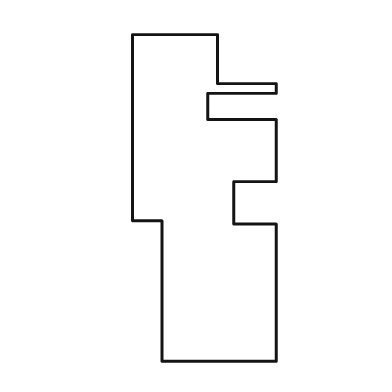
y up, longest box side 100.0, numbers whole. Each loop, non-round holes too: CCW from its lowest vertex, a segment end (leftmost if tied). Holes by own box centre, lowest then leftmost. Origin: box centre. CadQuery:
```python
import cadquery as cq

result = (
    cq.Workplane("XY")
    .moveTo(-13.0, -50.0)
    .lineTo(22.0, -50.0)
    .lineTo(22.0, -8.0)
    .lineTo(9.0, -8.0)
    .lineTo(9.0, 5.0)
    .lineTo(22.0, 5.0)
    .lineTo(22.0, 24.0)
    .lineTo(1.0, 24.0)
    .lineTo(1.0, 32.0)
    .lineTo(22.0, 32.0)
    .lineTo(22.0, 35.0)
    .lineTo(4.0, 35.0)
    .lineTo(4.0, 50.0)
    .lineTo(-22.0, 50.0)
    .lineTo(-22.0, -7.0)
    .lineTo(-13.0, -7.0)
    .close()
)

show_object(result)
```